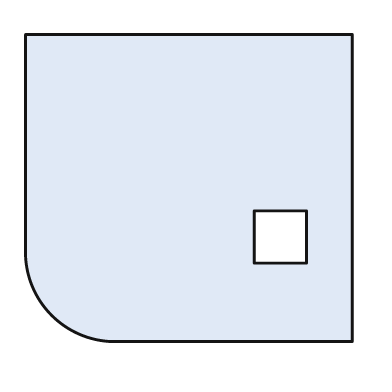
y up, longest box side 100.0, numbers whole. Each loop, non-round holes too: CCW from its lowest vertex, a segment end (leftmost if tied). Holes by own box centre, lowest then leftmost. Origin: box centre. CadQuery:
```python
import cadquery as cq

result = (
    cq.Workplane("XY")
    .moveTo(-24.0, -47.0)
    .lineTo(50.0, -47.0)
    .lineTo(50.0, 47.0)
    .lineTo(-50.0, 47.0)
    .lineTo(-50.0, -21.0)
    .threePointArc((-42.0, -39.0), (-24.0, -47.0))
    .close()
    .moveTo(20.0, -23.0)
    .lineTo(36.0, -23.0)
    .lineTo(36.0, -7.0)
    .lineTo(20.0, -7.0)
    .close()
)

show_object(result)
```